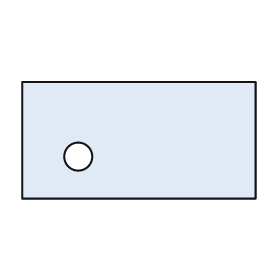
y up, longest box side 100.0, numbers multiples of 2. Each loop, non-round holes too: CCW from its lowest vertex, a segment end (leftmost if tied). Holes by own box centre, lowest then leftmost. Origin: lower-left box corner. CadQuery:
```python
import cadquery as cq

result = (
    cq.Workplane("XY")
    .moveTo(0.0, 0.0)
    .lineTo(100.0, 0.0)
    .lineTo(100.0, 50.0)
    .lineTo(0.0, 50.0)
    .close()
    .moveTo(24.0, 18.0)
    .circle(6.0)
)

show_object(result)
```